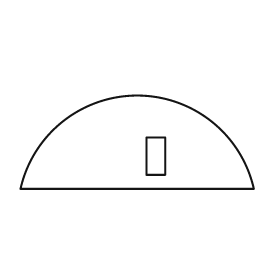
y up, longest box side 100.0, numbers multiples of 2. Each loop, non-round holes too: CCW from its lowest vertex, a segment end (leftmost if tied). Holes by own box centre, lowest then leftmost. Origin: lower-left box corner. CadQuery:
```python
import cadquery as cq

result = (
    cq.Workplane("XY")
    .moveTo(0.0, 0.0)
    .lineTo(100.0, 0.0)
    .threePointArc((50.0, 40.0), (0.0, 0.0))
    .close()
    .moveTo(54.0, 6.0)
    .lineTo(62.0, 6.0)
    .lineTo(62.0, 22.0)
    .lineTo(54.0, 22.0)
    .close()
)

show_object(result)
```